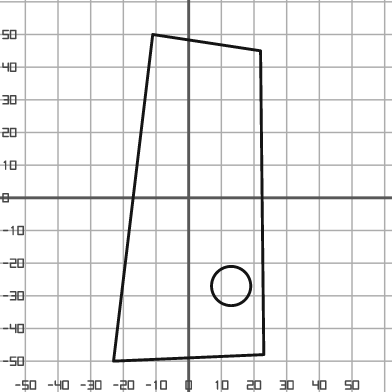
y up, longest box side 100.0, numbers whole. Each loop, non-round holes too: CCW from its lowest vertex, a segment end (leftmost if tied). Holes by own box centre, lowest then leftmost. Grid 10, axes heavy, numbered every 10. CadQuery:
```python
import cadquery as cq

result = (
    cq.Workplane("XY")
    .moveTo(-23.0, -50.0)
    .lineTo(23.0, -48.0)
    .lineTo(22.0, 45.0)
    .lineTo(-11.0, 50.0)
    .close()
    .moveTo(13.0, -27.0)
    .circle(6.0)
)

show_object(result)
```